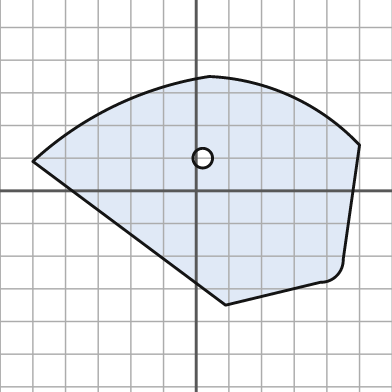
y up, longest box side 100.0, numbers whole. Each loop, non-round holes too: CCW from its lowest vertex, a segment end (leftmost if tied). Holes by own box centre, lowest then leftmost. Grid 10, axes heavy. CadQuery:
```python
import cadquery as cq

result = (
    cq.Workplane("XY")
    .moveTo(9.0, -35.0)
    .lineTo(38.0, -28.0)
    .threePointArc((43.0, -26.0), (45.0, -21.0))
    .lineTo(50.0, 14.0)
    .threePointArc((29.0, 29.0), (4.0, 35.0))
    .threePointArc((-25.0, 26.0), (-50.0, 9.0))
    .close()
    .moveTo(2.0, 10.0)
    .circle(3.0)
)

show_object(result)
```